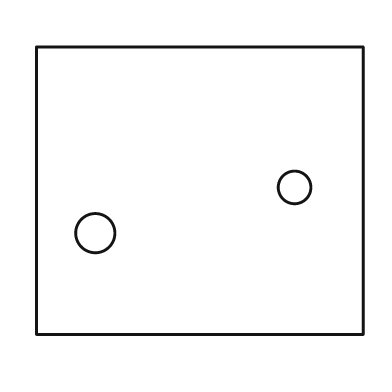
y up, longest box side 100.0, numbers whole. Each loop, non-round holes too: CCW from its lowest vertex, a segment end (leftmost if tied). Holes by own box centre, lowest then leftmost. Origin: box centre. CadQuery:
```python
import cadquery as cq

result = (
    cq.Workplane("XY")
    .moveTo(-50.0, -44.0)
    .lineTo(50.0, -44.0)
    .lineTo(50.0, 44.0)
    .lineTo(-50.0, 44.0)
    .close()
    .moveTo(-32.0, -13.0)
    .circle(6.0)
    .moveTo(29.0, 1.0)
    .circle(5.0)
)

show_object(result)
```